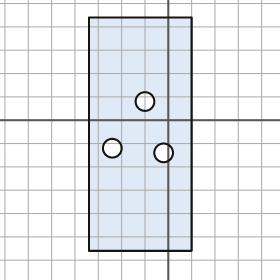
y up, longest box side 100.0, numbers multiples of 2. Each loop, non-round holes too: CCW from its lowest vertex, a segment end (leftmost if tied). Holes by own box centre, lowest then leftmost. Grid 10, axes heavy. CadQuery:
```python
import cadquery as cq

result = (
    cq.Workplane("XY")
    .moveTo(-34.0, -56.0)
    .lineTo(10.0, -56.0)
    .lineTo(10.0, 44.0)
    .lineTo(-34.0, 44.0)
    .close()
    .moveTo(-2.0, -14.0)
    .circle(4.0)
    .moveTo(-24.0, -12.0)
    .circle(4.0)
    .moveTo(-10.0, 8.0)
    .circle(4.0)
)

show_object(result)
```